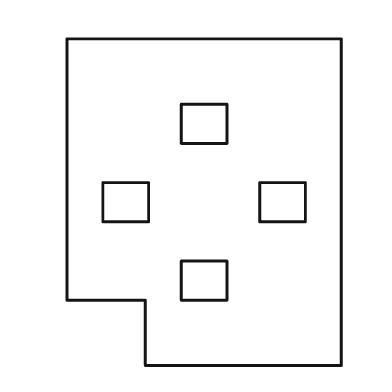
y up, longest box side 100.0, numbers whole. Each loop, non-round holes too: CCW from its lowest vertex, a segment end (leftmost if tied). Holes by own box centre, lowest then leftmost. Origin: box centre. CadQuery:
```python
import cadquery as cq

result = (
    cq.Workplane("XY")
    .moveTo(-18.0, -50.0)
    .lineTo(42.0, -50.0)
    .lineTo(42.0, 50.0)
    .lineTo(-42.0, 50.0)
    .lineTo(-42.0, -30.0)
    .lineTo(-18.0, -30.0)
    .close()
    .moveTo(-7.0, -30.0)
    .lineTo(7.0, -30.0)
    .lineTo(7.0, -18.0)
    .lineTo(-7.0, -18.0)
    .close()
    .moveTo(-31.0, -6.0)
    .lineTo(-17.0, -6.0)
    .lineTo(-17.0, 6.0)
    .lineTo(-31.0, 6.0)
    .close()
    .moveTo(17.0, -6.0)
    .lineTo(31.0, -6.0)
    .lineTo(31.0, 6.0)
    .lineTo(17.0, 6.0)
    .close()
    .moveTo(-7.0, 18.0)
    .lineTo(7.0, 18.0)
    .lineTo(7.0, 30.0)
    .lineTo(-7.0, 30.0)
    .close()
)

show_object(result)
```